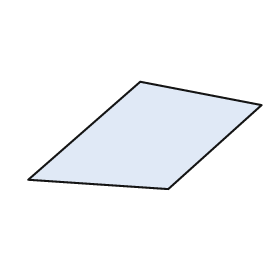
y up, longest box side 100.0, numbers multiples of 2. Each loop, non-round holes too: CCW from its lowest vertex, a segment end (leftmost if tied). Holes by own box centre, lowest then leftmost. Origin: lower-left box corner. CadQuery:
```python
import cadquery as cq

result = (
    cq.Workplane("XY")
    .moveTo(60.0, 0.0)
    .lineTo(100.0, 36.0)
    .lineTo(48.0, 46.0)
    .lineTo(0.0, 4.0)
    .close()
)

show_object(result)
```